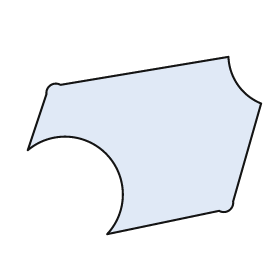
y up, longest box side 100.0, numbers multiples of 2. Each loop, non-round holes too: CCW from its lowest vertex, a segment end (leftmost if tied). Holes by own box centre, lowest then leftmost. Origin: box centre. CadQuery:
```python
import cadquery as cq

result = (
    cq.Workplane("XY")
    .moveTo(-16.0, -38.0)
    .lineTo(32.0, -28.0)
    .threePointArc((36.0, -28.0), (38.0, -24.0))
    .lineTo(50.0, 18.0)
    .threePointArc((40.0, 26.0), (36.0, 38.0))
    .lineTo(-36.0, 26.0)
    .threePointArc((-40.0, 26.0), (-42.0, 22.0))
    .lineTo(-50.0, -2.0)
    .threePointArc((-16.0, -4.0), (-16.0, -38.0))
    .close()
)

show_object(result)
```